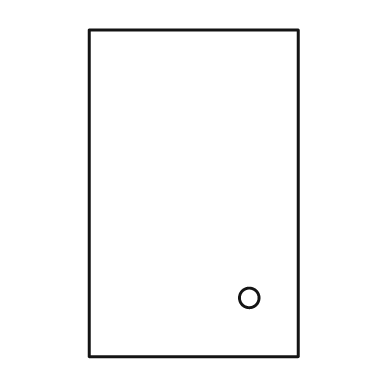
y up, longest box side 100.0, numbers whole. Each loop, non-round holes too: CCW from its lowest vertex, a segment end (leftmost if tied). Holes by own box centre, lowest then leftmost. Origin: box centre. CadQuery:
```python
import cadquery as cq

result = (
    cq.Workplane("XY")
    .moveTo(-32.0, -50.0)
    .lineTo(32.0, -50.0)
    .lineTo(32.0, 50.0)
    .lineTo(-32.0, 50.0)
    .close()
    .moveTo(17.0, -32.0)
    .circle(3.0)
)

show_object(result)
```